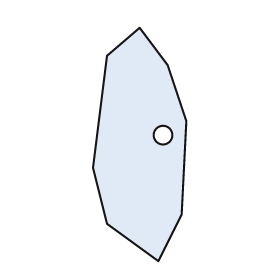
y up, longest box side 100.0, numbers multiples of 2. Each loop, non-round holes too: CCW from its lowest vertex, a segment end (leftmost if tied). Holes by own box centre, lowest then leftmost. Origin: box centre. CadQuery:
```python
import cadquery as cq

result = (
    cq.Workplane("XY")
    .moveTo(8.0, -50.0)
    .lineTo(18.0, -30.0)
    .lineTo(20.0, 10.0)
    .lineTo(12.0, 34.0)
    .lineTo(0.0, 50.0)
    .lineTo(-14.0, 38.0)
    .lineTo(-20.0, -10.0)
    .lineTo(-14.0, -34.0)
    .close()
    .moveTo(10.0, 4.0)
    .circle(4.0)
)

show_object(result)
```